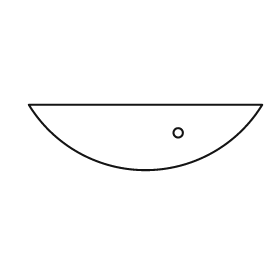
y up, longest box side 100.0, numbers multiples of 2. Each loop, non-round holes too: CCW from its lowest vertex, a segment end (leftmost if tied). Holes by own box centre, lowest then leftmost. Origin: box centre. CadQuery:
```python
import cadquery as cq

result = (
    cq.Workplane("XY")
    .moveTo(-50.0, 14.0)
    .threePointArc((0.0, -14.0), (50.0, 14.0))
    .close()
    .moveTo(14.0, 2.0)
    .circle(2.0)
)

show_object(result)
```